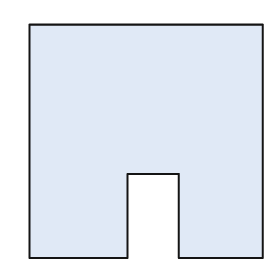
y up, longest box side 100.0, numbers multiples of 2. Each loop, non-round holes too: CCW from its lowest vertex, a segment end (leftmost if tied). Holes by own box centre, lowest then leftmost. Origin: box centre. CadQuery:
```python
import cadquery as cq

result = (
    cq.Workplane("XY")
    .moveTo(-50.0, -50.0)
    .lineTo(-8.0, -50.0)
    .lineTo(-8.0, -14.0)
    .lineTo(14.0, -14.0)
    .lineTo(14.0, -50.0)
    .lineTo(50.0, -50.0)
    .lineTo(50.0, 50.0)
    .lineTo(-50.0, 50.0)
    .close()
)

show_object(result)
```